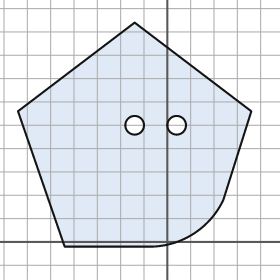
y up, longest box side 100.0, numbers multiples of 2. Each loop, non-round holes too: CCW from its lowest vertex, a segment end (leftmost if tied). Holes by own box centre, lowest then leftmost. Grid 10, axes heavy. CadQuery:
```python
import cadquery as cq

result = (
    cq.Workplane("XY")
    .moveTo(-44.0, -2.0)
    .lineTo(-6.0, -2.0)
    .threePointArc((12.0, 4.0), (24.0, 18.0))
    .lineTo(36.0, 56.0)
    .lineTo(-14.0, 94.0)
    .lineTo(-64.0, 56.0)
    .close()
    .moveTo(-14.0, 50.0)
    .circle(4.0)
    .moveTo(4.0, 50.0)
    .circle(4.0)
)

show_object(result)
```